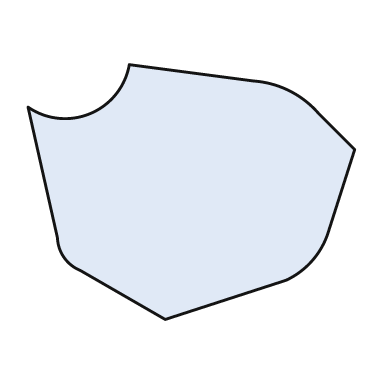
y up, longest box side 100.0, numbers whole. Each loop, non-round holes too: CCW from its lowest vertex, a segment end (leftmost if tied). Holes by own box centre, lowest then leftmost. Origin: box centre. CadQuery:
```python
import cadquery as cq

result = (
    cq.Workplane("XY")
    .moveTo(-8.0, -39.0)
    .lineTo(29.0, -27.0)
    .threePointArc((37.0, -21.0), (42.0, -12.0))
    .lineTo(50.0, 13.0)
    .lineTo(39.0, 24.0)
    .threePointArc((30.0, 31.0), (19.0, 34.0))
    .lineTo(-19.0, 39.0)
    .threePointArc((-31.0, 24.0), (-50.0, 26.0))
    .lineTo(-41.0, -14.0)
    .threePointArc((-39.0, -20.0), (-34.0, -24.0))
    .close()
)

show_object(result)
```